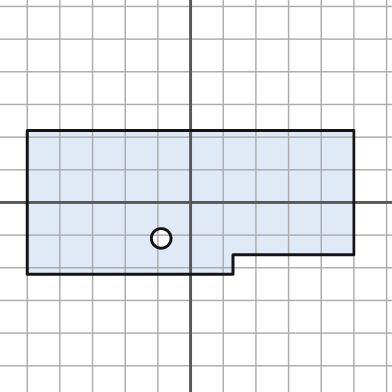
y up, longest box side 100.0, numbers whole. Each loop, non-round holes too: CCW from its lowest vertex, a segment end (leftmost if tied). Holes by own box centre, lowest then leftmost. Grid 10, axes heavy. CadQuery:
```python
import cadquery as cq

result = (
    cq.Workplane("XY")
    .moveTo(-50.0, -22.0)
    .lineTo(13.0, -22.0)
    .lineTo(13.0, -16.0)
    .lineTo(50.0, -16.0)
    .lineTo(50.0, 22.0)
    .lineTo(-50.0, 22.0)
    .close()
    .moveTo(-9.0, -11.0)
    .circle(3.0)
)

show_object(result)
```